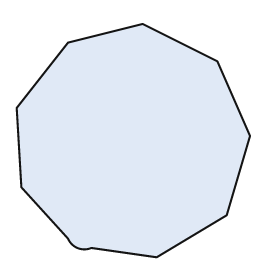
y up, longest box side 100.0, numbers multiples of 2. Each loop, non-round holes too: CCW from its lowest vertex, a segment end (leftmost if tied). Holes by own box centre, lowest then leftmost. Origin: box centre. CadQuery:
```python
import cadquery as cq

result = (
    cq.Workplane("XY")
    .moveTo(10.0, -50.0)
    .lineTo(40.0, -32.0)
    .lineTo(50.0, 2.0)
    .lineTo(36.0, 34.0)
    .lineTo(4.0, 50.0)
    .lineTo(-28.0, 42.0)
    .lineTo(-50.0, 14.0)
    .lineTo(-48.0, -20.0)
    .lineTo(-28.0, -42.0)
    .threePointArc((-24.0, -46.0), (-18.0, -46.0))
    .close()
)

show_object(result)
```